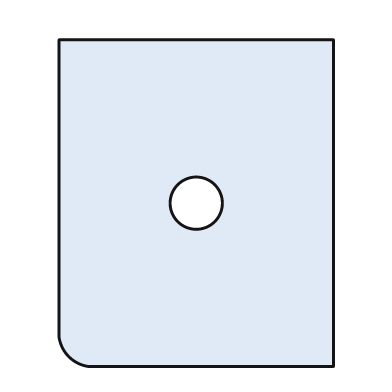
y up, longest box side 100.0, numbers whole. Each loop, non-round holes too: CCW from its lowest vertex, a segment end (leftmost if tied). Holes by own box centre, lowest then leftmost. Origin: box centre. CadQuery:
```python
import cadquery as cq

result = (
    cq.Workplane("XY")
    .moveTo(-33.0, -50.0)
    .lineTo(42.0, -50.0)
    .lineTo(42.0, 50.0)
    .lineTo(-42.0, 50.0)
    .lineTo(-42.0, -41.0)
    .threePointArc((-39.0, -47.0), (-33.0, -50.0))
    .close()
    .moveTo(0.0, 0.0)
    .circle(8.0)
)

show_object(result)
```